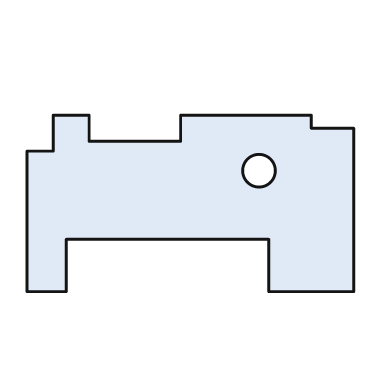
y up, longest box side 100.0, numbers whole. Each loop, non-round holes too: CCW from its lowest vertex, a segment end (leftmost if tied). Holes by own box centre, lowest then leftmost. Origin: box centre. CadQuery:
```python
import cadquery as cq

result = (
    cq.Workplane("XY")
    .moveTo(-50.0, -27.0)
    .lineTo(-38.0, -27.0)
    .lineTo(-38.0, -11.0)
    .lineTo(24.0, -11.0)
    .lineTo(24.0, -27.0)
    .lineTo(50.0, -27.0)
    .lineTo(50.0, 23.0)
    .lineTo(37.0, 23.0)
    .lineTo(37.0, 27.0)
    .lineTo(-3.0, 27.0)
    .lineTo(-3.0, 19.0)
    .lineTo(-31.0, 19.0)
    .lineTo(-31.0, 27.0)
    .lineTo(-42.0, 27.0)
    .lineTo(-42.0, 16.0)
    .lineTo(-50.0, 16.0)
    .close()
    .moveTo(21.0, 10.0)
    .circle(5.0)
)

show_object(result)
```